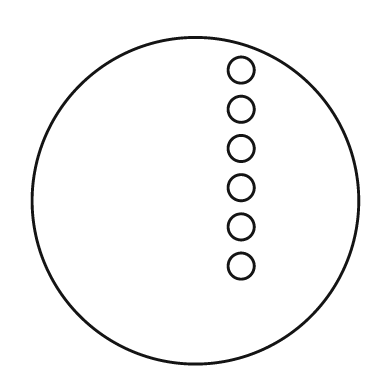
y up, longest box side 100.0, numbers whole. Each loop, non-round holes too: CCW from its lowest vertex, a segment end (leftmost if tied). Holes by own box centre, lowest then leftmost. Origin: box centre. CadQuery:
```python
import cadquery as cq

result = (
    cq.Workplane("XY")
    .moveTo(0.0, 0.0)
    .circle(50.0)
    .moveTo(14.0, -20.0)
    .circle(4.0)
    .moveTo(14.0, -8.0)
    .circle(4.0)
    .moveTo(14.0, 4.0)
    .circle(4.0)
    .moveTo(14.0, 16.0)
    .circle(4.0)
    .moveTo(14.0, 28.0)
    .circle(4.0)
    .moveTo(14.0, 40.0)
    .circle(4.0)
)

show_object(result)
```